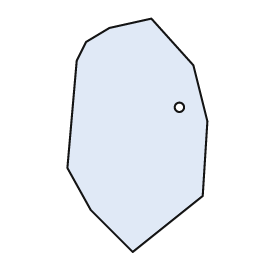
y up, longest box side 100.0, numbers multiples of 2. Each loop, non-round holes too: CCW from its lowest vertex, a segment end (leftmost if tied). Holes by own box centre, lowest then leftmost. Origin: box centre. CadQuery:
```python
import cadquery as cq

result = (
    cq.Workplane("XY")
    .moveTo(-2.0, -50.0)
    .lineTo(28.0, -26.0)
    .lineTo(30.0, 6.0)
    .lineTo(24.0, 30.0)
    .lineTo(6.0, 50.0)
    .lineTo(-12.0, 46.0)
    .lineTo(-22.0, 40.0)
    .lineTo(-26.0, 32.0)
    .lineTo(-30.0, -14.0)
    .lineTo(-20.0, -32.0)
    .close()
    .moveTo(18.0, 12.0)
    .circle(2.0)
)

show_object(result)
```